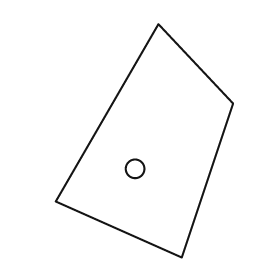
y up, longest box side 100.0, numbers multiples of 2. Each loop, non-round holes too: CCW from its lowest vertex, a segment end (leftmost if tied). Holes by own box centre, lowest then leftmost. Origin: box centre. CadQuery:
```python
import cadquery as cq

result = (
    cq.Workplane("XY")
    .moveTo(16.0, -50.0)
    .lineTo(38.0, 16.0)
    .lineTo(6.0, 50.0)
    .lineTo(-38.0, -26.0)
    .close()
    .moveTo(-4.0, -12.0)
    .circle(4.0)
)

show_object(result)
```